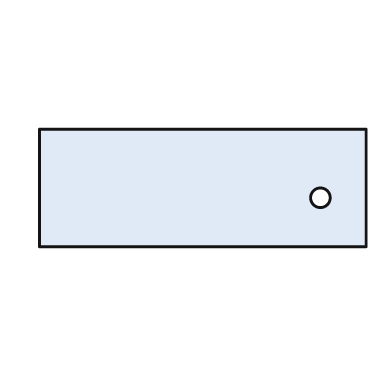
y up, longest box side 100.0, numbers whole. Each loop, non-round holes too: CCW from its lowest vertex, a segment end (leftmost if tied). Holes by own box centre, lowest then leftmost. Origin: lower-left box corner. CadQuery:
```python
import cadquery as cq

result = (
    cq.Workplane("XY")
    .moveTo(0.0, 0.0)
    .lineTo(100.0, 0.0)
    .lineTo(100.0, 36.0)
    .lineTo(0.0, 36.0)
    .close()
    .moveTo(86.0, 15.0)
    .circle(3.0)
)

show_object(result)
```